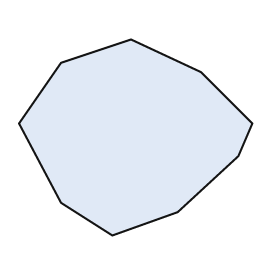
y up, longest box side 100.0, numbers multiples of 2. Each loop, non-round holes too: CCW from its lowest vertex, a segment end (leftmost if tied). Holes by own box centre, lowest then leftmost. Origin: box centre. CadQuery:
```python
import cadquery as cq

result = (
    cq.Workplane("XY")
    .moveTo(-10.0, -42.0)
    .lineTo(18.0, -32.0)
    .lineTo(44.0, -8.0)
    .lineTo(50.0, 6.0)
    .lineTo(28.0, 28.0)
    .lineTo(-2.0, 42.0)
    .lineTo(-32.0, 32.0)
    .lineTo(-50.0, 6.0)
    .lineTo(-32.0, -28.0)
    .close()
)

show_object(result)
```